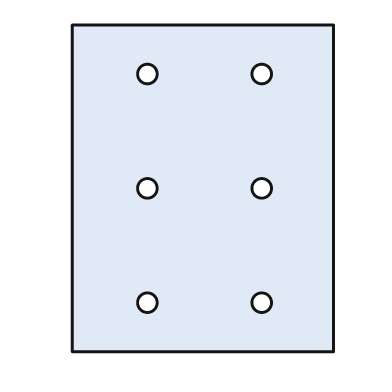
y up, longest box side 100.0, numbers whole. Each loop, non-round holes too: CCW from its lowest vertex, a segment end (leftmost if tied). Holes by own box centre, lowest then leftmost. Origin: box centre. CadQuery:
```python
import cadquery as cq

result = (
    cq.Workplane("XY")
    .moveTo(-40.0, -50.0)
    .lineTo(40.0, -50.0)
    .lineTo(40.0, 50.0)
    .lineTo(-40.0, 50.0)
    .close()
    .moveTo(-17.0, -35.0)
    .circle(3.0)
    .moveTo(18.0, -35.0)
    .circle(3.0)
    .moveTo(-17.0, 0.0)
    .circle(3.0)
    .moveTo(18.0, 0.0)
    .circle(3.0)
    .moveTo(-17.0, 35.0)
    .circle(3.0)
    .moveTo(18.0, 35.0)
    .circle(3.0)
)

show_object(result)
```